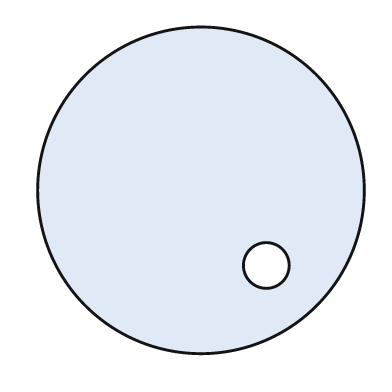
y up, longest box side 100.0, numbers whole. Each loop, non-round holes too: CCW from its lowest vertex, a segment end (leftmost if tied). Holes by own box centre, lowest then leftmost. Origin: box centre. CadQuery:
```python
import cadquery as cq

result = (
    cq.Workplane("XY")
    .moveTo(0.0, 0.0)
    .circle(50.0)
    .moveTo(20.0, -23.0)
    .circle(7.0)
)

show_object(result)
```